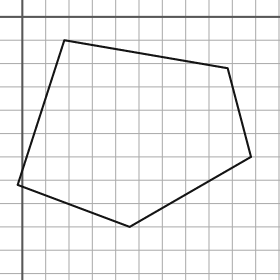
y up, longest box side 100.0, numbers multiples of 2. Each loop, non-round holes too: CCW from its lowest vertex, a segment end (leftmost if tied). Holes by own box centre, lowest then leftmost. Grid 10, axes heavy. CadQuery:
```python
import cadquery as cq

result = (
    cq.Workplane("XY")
    .moveTo(46.0, -90.0)
    .lineTo(98.0, -60.0)
    .lineTo(88.0, -22.0)
    .lineTo(18.0, -10.0)
    .lineTo(-2.0, -72.0)
    .close()
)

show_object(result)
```